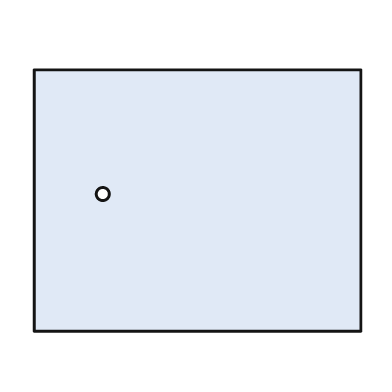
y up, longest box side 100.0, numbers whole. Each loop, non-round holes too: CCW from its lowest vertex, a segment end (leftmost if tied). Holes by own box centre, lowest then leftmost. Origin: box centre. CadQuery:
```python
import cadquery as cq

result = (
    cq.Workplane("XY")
    .moveTo(-50.0, -40.0)
    .lineTo(50.0, -40.0)
    .lineTo(50.0, 40.0)
    .lineTo(-50.0, 40.0)
    .close()
    .moveTo(-29.0, 2.0)
    .circle(2.0)
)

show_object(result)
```